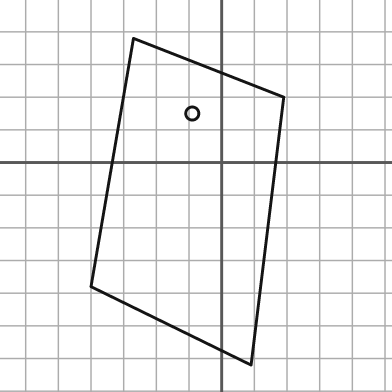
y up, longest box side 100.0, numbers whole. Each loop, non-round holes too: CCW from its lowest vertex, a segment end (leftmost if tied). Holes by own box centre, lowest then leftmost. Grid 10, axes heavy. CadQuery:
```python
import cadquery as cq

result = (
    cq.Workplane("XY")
    .moveTo(9.0, -62.0)
    .lineTo(19.0, 20.0)
    .lineTo(-27.0, 38.0)
    .lineTo(-40.0, -38.0)
    .close()
    .moveTo(-9.0, 15.0)
    .circle(2.0)
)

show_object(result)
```